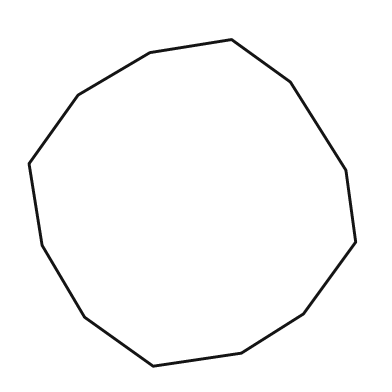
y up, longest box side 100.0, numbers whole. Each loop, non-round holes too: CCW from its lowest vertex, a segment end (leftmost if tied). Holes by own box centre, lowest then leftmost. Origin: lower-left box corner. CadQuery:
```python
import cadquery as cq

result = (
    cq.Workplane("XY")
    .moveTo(38.0, 0.0)
    .lineTo(65.0, 4.0)
    .lineTo(84.0, 16.0)
    .lineTo(100.0, 38.0)
    .lineTo(97.0, 60.0)
    .lineTo(80.0, 87.0)
    .lineTo(62.0, 100.0)
    .lineTo(37.0, 96.0)
    .lineTo(15.0, 83.0)
    .lineTo(0.0, 62.0)
    .lineTo(4.0, 37.0)
    .lineTo(17.0, 15.0)
    .close()
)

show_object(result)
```